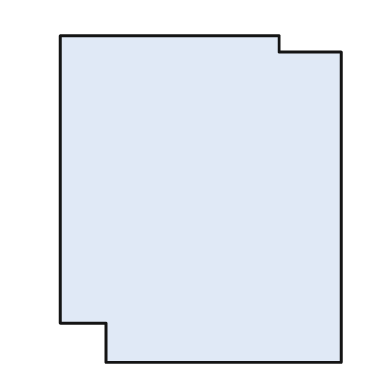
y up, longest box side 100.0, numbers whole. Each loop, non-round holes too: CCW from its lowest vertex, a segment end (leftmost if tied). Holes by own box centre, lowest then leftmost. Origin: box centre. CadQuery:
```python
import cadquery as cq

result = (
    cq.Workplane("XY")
    .moveTo(-29.0, -50.0)
    .lineTo(43.0, -50.0)
    .lineTo(43.0, 45.0)
    .lineTo(24.0, 45.0)
    .lineTo(24.0, 50.0)
    .lineTo(-43.0, 50.0)
    .lineTo(-43.0, -38.0)
    .lineTo(-29.0, -38.0)
    .close()
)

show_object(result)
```